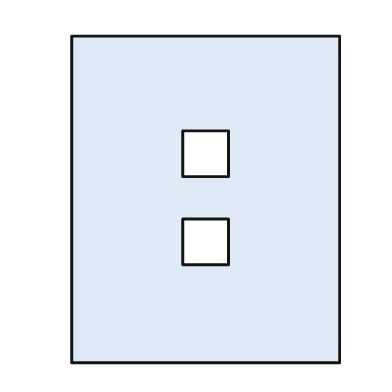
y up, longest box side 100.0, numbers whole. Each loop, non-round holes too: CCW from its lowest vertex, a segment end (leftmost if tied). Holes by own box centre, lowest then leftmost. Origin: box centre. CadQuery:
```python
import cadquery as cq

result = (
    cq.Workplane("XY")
    .moveTo(-41.0, -50.0)
    .lineTo(41.0, -50.0)
    .lineTo(41.0, 50.0)
    .lineTo(-41.0, 50.0)
    .close()
    .moveTo(-7.0, -20.0)
    .lineTo(7.0, -20.0)
    .lineTo(7.0, -6.0)
    .lineTo(-7.0, -6.0)
    .close()
    .moveTo(-7.0, 7.0)
    .lineTo(7.0, 7.0)
    .lineTo(7.0, 21.0)
    .lineTo(-7.0, 21.0)
    .close()
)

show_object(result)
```